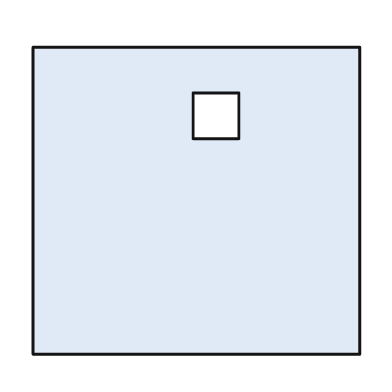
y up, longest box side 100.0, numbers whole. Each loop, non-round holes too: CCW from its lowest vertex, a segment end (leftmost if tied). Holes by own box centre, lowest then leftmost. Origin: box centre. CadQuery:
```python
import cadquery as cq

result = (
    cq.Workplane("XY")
    .moveTo(-50.0, -47.0)
    .lineTo(50.0, -47.0)
    .lineTo(50.0, 47.0)
    .lineTo(-50.0, 47.0)
    .close()
    .moveTo(-1.0, 19.0)
    .lineTo(13.0, 19.0)
    .lineTo(13.0, 33.0)
    .lineTo(-1.0, 33.0)
    .close()
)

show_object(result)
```